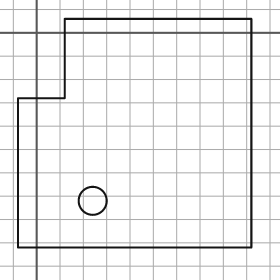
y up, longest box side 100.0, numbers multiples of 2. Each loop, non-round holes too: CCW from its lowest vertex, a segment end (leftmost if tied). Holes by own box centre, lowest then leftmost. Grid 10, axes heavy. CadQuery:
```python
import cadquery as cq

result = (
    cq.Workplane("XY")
    .moveTo(-8.0, -92.0)
    .lineTo(92.0, -92.0)
    .lineTo(92.0, 6.0)
    .lineTo(12.0, 6.0)
    .lineTo(12.0, -28.0)
    .lineTo(-8.0, -28.0)
    .close()
    .moveTo(24.0, -72.0)
    .circle(6.0)
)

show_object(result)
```